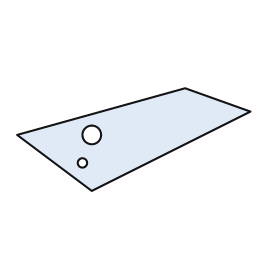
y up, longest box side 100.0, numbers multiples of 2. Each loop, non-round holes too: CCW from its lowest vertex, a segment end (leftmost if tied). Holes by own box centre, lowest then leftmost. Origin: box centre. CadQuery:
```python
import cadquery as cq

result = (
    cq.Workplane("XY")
    .moveTo(-18.0, -22.0)
    .lineTo(50.0, 12.0)
    .lineTo(22.0, 22.0)
    .lineTo(-50.0, 2.0)
    .close()
    .moveTo(-22.0, -10.0)
    .circle(2.0)
    .moveTo(-18.0, 2.0)
    .circle(4.0)
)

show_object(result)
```